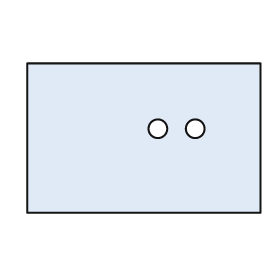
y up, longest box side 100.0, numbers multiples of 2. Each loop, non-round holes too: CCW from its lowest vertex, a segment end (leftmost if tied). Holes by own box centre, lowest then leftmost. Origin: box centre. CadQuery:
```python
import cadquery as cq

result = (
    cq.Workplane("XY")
    .moveTo(-50.0, -32.0)
    .lineTo(50.0, -32.0)
    .lineTo(50.0, 32.0)
    .lineTo(-50.0, 32.0)
    .close()
    .moveTo(6.0, 4.0)
    .circle(4.0)
    .moveTo(22.0, 4.0)
    .circle(4.0)
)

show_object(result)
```